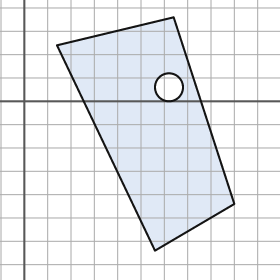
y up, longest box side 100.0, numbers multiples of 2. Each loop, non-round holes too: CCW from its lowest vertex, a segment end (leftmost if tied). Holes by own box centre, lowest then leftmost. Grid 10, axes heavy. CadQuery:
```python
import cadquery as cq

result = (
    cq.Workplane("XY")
    .moveTo(56.0, -64.0)
    .lineTo(90.0, -44.0)
    .lineTo(64.0, 36.0)
    .lineTo(14.0, 24.0)
    .close()
    .moveTo(62.0, 6.0)
    .circle(6.0)
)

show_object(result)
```